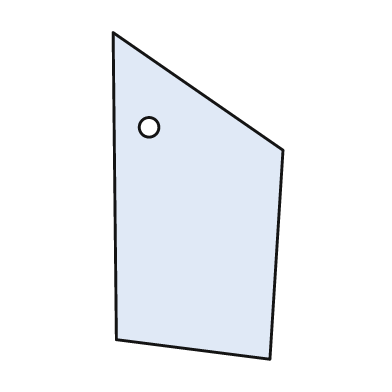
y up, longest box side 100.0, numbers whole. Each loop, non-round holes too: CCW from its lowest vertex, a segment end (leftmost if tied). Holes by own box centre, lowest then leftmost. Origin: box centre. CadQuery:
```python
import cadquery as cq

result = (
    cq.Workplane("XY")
    .moveTo(22.0, -50.0)
    .lineTo(26.0, 14.0)
    .lineTo(-26.0, 50.0)
    .lineTo(-25.0, -44.0)
    .close()
    .moveTo(-15.0, 21.0)
    .circle(3.0)
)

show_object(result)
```